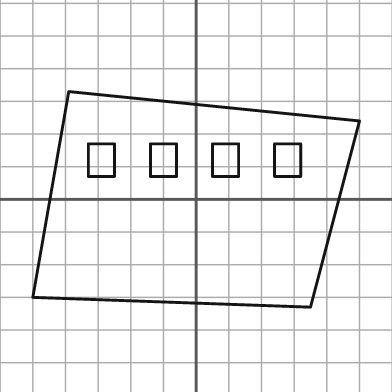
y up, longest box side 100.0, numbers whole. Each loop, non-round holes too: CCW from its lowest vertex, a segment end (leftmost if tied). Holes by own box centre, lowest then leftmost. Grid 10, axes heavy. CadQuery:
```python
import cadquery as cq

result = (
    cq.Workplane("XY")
    .moveTo(35.0, -33.0)
    .lineTo(50.0, 24.0)
    .lineTo(-39.0, 33.0)
    .lineTo(-50.0, -30.0)
    .close()
    .moveTo(-33.0, 7.0)
    .lineTo(-25.0, 7.0)
    .lineTo(-25.0, 17.0)
    .lineTo(-33.0, 17.0)
    .close()
    .moveTo(-14.0, 7.0)
    .lineTo(-6.0, 7.0)
    .lineTo(-6.0, 17.0)
    .lineTo(-14.0, 17.0)
    .close()
    .moveTo(5.0, 7.0)
    .lineTo(13.0, 7.0)
    .lineTo(13.0, 17.0)
    .lineTo(5.0, 17.0)
    .close()
    .moveTo(24.0, 7.0)
    .lineTo(32.0, 7.0)
    .lineTo(32.0, 17.0)
    .lineTo(24.0, 17.0)
    .close()
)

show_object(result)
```